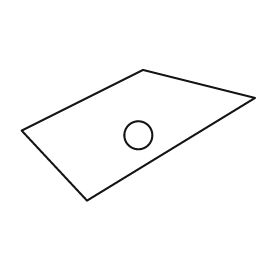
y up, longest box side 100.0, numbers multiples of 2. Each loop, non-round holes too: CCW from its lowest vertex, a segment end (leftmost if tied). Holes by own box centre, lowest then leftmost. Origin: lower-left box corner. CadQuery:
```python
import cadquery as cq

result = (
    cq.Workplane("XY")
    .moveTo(28.0, 0.0)
    .lineTo(100.0, 44.0)
    .lineTo(52.0, 56.0)
    .lineTo(0.0, 30.0)
    .close()
    .moveTo(50.0, 28.0)
    .circle(6.0)
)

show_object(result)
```